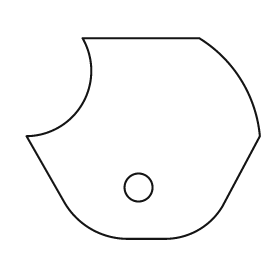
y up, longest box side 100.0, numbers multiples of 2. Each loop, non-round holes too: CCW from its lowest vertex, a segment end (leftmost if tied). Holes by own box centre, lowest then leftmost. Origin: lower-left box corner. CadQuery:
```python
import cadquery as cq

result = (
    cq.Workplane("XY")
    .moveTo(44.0, 0.0)
    .lineTo(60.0, 0.0)
    .threePointArc((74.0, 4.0), (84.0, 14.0))
    .lineTo(100.0, 44.0)
    .threePointArc((92.0, 68.0), (74.0, 86.0))
    .lineTo(24.0, 86.0)
    .threePointArc((24.0, 58.0), (0.0, 44.0))
    .lineTo(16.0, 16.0)
    .threePointArc((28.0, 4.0), (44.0, 0.0))
    .close()
    .moveTo(48.0, 22.0)
    .circle(6.0)
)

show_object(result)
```